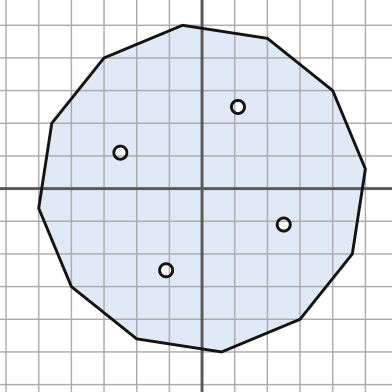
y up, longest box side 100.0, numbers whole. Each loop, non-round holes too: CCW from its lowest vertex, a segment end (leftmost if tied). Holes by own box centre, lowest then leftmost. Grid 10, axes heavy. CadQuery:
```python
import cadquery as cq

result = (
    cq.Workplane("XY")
    .moveTo(6.0, -50.0)
    .lineTo(30.0, -40.0)
    .lineTo(46.0, -20.0)
    .lineTo(50.0, 6.0)
    .lineTo(40.0, 30.0)
    .lineTo(20.0, 46.0)
    .lineTo(-6.0, 50.0)
    .lineTo(-30.0, 40.0)
    .lineTo(-46.0, 20.0)
    .lineTo(-50.0, -6.0)
    .lineTo(-40.0, -30.0)
    .lineTo(-20.0, -46.0)
    .close()
    .moveTo(-11.0, -25.0)
    .circle(2.0)
    .moveTo(25.0, -11.0)
    .circle(2.0)
    .moveTo(-25.0, 11.0)
    .circle(2.0)
    .moveTo(11.0, 25.0)
    .circle(2.0)
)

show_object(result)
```